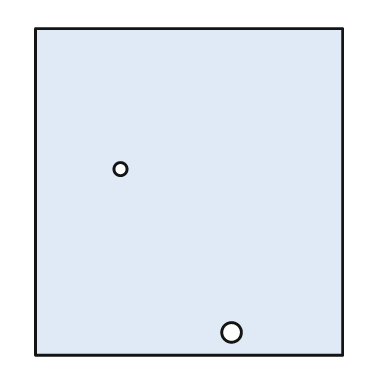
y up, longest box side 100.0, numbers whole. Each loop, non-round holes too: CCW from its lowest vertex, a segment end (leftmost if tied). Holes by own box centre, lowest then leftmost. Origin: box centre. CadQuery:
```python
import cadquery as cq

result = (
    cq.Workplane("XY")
    .moveTo(-47.0, -50.0)
    .lineTo(47.0, -50.0)
    .lineTo(47.0, 50.0)
    .lineTo(-47.0, 50.0)
    .close()
    .moveTo(13.0, -43.0)
    .circle(3.0)
    .moveTo(-21.0, 7.0)
    .circle(2.0)
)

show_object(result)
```